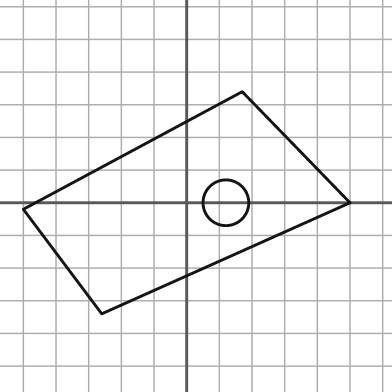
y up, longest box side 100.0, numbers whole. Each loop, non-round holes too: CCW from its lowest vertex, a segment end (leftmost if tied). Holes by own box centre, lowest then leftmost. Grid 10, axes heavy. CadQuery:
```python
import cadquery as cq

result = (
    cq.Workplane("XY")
    .moveTo(-26.0, -34.0)
    .lineTo(50.0, 0.0)
    .lineTo(17.0, 34.0)
    .lineTo(-50.0, -2.0)
    .close()
    .moveTo(12.0, 0.0)
    .circle(7.0)
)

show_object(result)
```